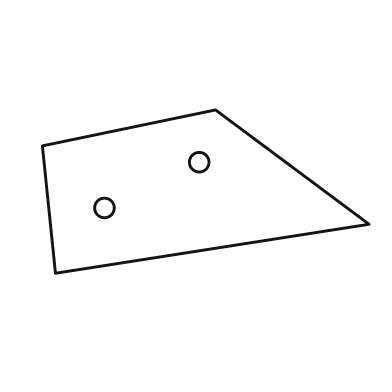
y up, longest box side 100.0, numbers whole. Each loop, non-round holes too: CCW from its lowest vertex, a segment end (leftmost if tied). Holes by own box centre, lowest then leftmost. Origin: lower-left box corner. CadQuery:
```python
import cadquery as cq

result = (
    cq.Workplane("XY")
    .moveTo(4.0, 0.0)
    .lineTo(100.0, 15.0)
    .lineTo(53.0, 50.0)
    .lineTo(0.0, 39.0)
    .close()
    .moveTo(19.0, 20.0)
    .circle(3.0)
    .moveTo(48.0, 34.0)
    .circle(3.0)
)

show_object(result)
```